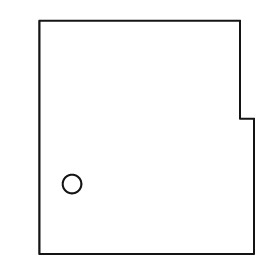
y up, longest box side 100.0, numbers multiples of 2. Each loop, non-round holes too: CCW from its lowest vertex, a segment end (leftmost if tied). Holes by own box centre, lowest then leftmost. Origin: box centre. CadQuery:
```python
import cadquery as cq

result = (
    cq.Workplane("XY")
    .moveTo(-46.0, -50.0)
    .lineTo(46.0, -50.0)
    .lineTo(46.0, 8.0)
    .lineTo(40.0, 8.0)
    .lineTo(40.0, 50.0)
    .lineTo(-46.0, 50.0)
    .close()
    .moveTo(-32.0, -20.0)
    .circle(4.0)
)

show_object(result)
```